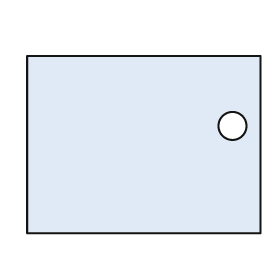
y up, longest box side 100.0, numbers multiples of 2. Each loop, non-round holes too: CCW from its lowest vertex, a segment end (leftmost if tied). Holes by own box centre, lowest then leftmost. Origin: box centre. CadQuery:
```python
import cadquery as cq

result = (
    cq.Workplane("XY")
    .moveTo(-50.0, -38.0)
    .lineTo(50.0, -38.0)
    .lineTo(50.0, 38.0)
    .lineTo(-50.0, 38.0)
    .close()
    .moveTo(38.0, 8.0)
    .circle(6.0)
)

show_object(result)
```